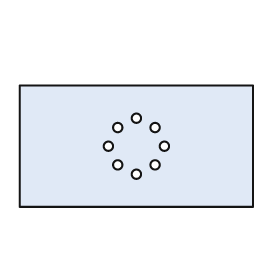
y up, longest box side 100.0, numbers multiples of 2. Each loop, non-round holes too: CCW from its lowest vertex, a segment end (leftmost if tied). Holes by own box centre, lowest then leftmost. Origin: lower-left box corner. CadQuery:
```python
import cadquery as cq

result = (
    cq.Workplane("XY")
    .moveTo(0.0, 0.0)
    .lineTo(100.0, 0.0)
    .lineTo(100.0, 52.0)
    .lineTo(0.0, 52.0)
    .close()
    .moveTo(50.0, 14.0)
    .circle(2.0)
    .moveTo(42.0, 18.0)
    .circle(2.0)
    .moveTo(58.0, 18.0)
    .circle(2.0)
    .moveTo(38.0, 26.0)
    .circle(2.0)
    .moveTo(62.0, 26.0)
    .circle(2.0)
    .moveTo(42.0, 34.0)
    .circle(2.0)
    .moveTo(58.0, 34.0)
    .circle(2.0)
    .moveTo(50.0, 38.0)
    .circle(2.0)
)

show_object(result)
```